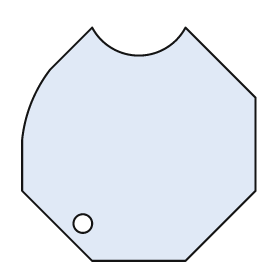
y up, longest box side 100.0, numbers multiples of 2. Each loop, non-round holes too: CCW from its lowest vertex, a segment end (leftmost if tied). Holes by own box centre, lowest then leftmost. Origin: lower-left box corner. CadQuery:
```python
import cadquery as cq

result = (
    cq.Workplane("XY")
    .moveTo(30.0, 0.0)
    .lineTo(70.0, 0.0)
    .lineTo(100.0, 30.0)
    .lineTo(100.0, 70.0)
    .lineTo(70.0, 100.0)
    .threePointArc((50.0, 88.0), (30.0, 100.0))
    .lineTo(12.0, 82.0)
    .threePointArc((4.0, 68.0), (0.0, 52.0))
    .lineTo(0.0, 30.0)
    .close()
    .moveTo(26.0, 16.0)
    .circle(4.0)
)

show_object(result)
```